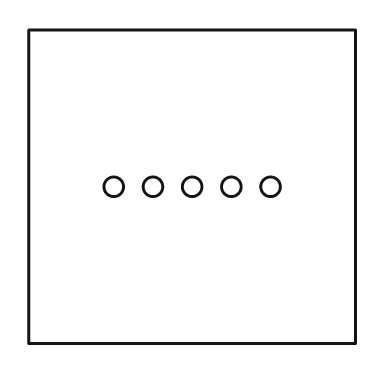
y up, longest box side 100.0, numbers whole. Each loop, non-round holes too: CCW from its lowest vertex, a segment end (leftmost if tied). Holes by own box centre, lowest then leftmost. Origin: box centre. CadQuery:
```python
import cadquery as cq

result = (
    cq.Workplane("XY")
    .moveTo(-50.0, -48.0)
    .lineTo(50.0, -48.0)
    .lineTo(50.0, 48.0)
    .lineTo(-50.0, 48.0)
    .close()
    .moveTo(-24.0, 0.0)
    .circle(3.0)
    .moveTo(-12.0, 0.0)
    .circle(3.0)
    .moveTo(0.0, 0.0)
    .circle(3.0)
    .moveTo(12.0, 0.0)
    .circle(3.0)
    .moveTo(24.0, 0.0)
    .circle(3.0)
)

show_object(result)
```